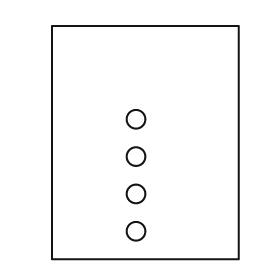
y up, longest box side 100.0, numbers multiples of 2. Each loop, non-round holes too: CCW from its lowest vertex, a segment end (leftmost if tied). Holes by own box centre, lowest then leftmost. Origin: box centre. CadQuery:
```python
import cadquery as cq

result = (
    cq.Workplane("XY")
    .moveTo(-40.0, -50.0)
    .lineTo(40.0, -50.0)
    .lineTo(40.0, 50.0)
    .lineTo(-40.0, 50.0)
    .close()
    .moveTo(-4.0, -38.0)
    .circle(4.0)
    .moveTo(-4.0, -22.0)
    .circle(4.0)
    .moveTo(-4.0, -6.0)
    .circle(4.0)
    .moveTo(-4.0, 10.0)
    .circle(4.0)
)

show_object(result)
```